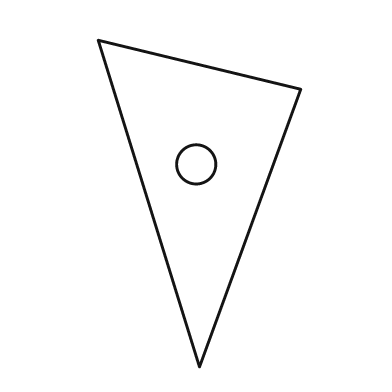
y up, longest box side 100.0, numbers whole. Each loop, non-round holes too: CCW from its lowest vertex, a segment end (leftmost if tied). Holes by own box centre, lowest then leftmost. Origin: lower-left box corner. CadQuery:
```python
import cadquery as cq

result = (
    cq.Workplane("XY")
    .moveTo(31.0, 0.0)
    .lineTo(62.0, 85.0)
    .lineTo(0.0, 100.0)
    .close()
    .moveTo(30.0, 62.0)
    .circle(6.0)
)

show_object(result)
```